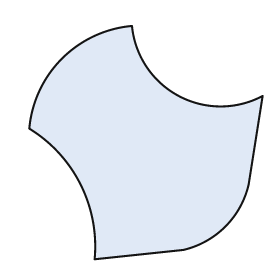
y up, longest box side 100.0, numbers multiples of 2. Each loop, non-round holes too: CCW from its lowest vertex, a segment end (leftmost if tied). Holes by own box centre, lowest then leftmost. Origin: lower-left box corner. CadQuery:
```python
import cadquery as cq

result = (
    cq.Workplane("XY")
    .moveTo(28.0, 0.0)
    .lineTo(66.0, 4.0)
    .threePointArc((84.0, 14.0), (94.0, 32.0))
    .lineTo(100.0, 70.0)
    .threePointArc((64.0, 70.0), (44.0, 100.0))
    .threePointArc((14.0, 86.0), (0.0, 56.0))
    .threePointArc((22.0, 32.0), (28.0, 0.0))
    .close()
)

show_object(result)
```